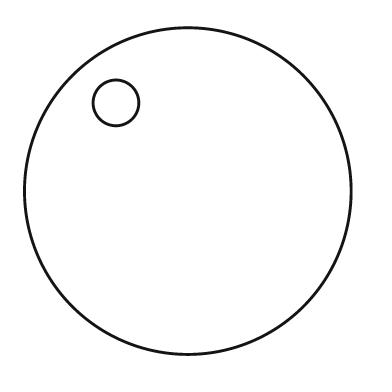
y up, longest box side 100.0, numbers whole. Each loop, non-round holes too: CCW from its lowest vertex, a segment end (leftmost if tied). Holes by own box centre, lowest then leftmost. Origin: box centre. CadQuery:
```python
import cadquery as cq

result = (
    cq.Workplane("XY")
    .moveTo(0.0, 0.0)
    .circle(50.0)
    .moveTo(-22.0, 27.0)
    .circle(7.0)
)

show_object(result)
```